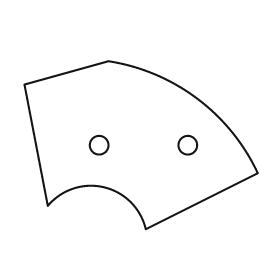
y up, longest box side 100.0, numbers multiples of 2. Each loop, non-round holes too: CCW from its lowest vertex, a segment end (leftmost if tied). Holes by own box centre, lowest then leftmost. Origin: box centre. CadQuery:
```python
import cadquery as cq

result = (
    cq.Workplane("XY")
    .moveTo(2.0, -36.0)
    .lineTo(50.0, -12.0)
    .threePointArc((24.0, 20.0), (-14.0, 36.0))
    .lineTo(-50.0, 26.0)
    .lineTo(-40.0, -26.0)
    .threePointArc((-16.0, -18.0), (2.0, -36.0))
    .close()
    .moveTo(-18.0, 0.0)
    .circle(4.0)
    .moveTo(20.0, 0.0)
    .circle(4.0)
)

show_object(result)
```